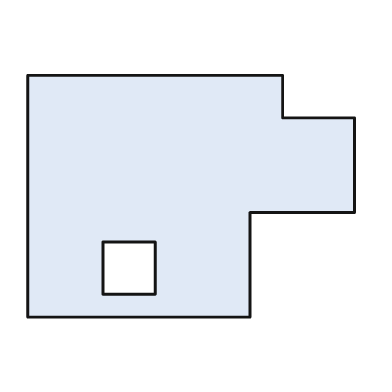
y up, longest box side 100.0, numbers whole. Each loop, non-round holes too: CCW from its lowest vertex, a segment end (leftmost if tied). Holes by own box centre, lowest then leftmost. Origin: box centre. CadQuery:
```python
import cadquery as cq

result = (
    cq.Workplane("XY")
    .moveTo(-50.0, -37.0)
    .lineTo(18.0, -37.0)
    .lineTo(18.0, -5.0)
    .lineTo(50.0, -5.0)
    .lineTo(50.0, 24.0)
    .lineTo(28.0, 24.0)
    .lineTo(28.0, 37.0)
    .lineTo(-50.0, 37.0)
    .close()
    .moveTo(-27.0, -30.0)
    .lineTo(-11.0, -30.0)
    .lineTo(-11.0, -14.0)
    .lineTo(-27.0, -14.0)
    .close()
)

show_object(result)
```